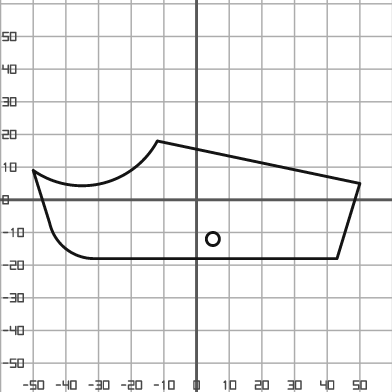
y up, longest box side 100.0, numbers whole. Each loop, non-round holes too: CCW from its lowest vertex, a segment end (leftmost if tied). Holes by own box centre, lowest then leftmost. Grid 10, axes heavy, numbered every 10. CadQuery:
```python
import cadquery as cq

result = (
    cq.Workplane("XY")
    .moveTo(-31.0, -18.0)
    .lineTo(43.0, -18.0)
    .lineTo(50.0, 5.0)
    .lineTo(-12.0, 18.0)
    .threePointArc((-29.0, 5.0), (-50.0, 9.0))
    .lineTo(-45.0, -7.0)
    .threePointArc((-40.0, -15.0), (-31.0, -18.0))
    .close()
    .moveTo(5.0, -12.0)
    .circle(2.0)
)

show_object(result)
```